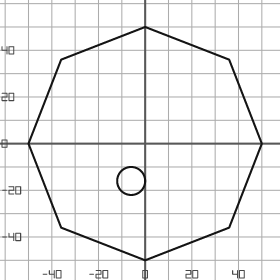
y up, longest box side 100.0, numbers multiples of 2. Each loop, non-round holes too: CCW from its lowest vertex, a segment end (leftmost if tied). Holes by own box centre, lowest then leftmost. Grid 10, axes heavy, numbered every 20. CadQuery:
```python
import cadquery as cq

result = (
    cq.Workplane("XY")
    .moveTo(0.0, -50.0)
    .lineTo(36.0, -36.0)
    .lineTo(50.0, 0.0)
    .lineTo(36.0, 36.0)
    .lineTo(0.0, 50.0)
    .lineTo(-36.0, 36.0)
    .lineTo(-50.0, 0.0)
    .lineTo(-36.0, -36.0)
    .close()
    .moveTo(-6.0, -16.0)
    .circle(6.0)
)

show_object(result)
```